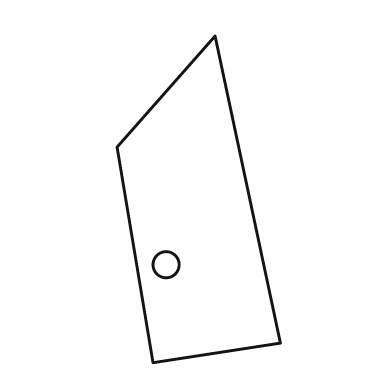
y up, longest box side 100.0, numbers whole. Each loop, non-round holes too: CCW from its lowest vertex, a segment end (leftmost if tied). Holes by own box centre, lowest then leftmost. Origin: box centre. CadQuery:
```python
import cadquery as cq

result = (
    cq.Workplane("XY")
    .moveTo(-14.0, -50.0)
    .lineTo(25.0, -44.0)
    .lineTo(5.0, 50.0)
    .lineTo(-25.0, 16.0)
    .close()
    .moveTo(-10.0, -20.0)
    .circle(4.0)
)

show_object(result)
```